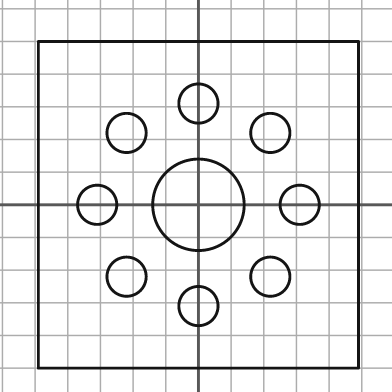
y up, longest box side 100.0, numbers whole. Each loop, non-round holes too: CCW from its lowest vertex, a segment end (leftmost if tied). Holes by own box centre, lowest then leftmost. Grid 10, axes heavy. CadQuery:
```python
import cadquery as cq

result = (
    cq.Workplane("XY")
    .moveTo(-49.0, -50.0)
    .lineTo(49.0, -50.0)
    .lineTo(49.0, 50.0)
    .lineTo(-49.0, 50.0)
    .close()
    .moveTo(0.0, -31.0)
    .circle(6.0)
    .moveTo(-22.0, -22.0)
    .circle(6.0)
    .moveTo(22.0, -22.0)
    .circle(6.0)
    .moveTo(-31.0, 0.0)
    .circle(6.0)
    .moveTo(0.0, 0.0)
    .circle(14.0)
    .moveTo(31.0, 0.0)
    .circle(6.0)
    .moveTo(-22.0, 22.0)
    .circle(6.0)
    .moveTo(22.0, 22.0)
    .circle(6.0)
    .moveTo(0.0, 31.0)
    .circle(6.0)
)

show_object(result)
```